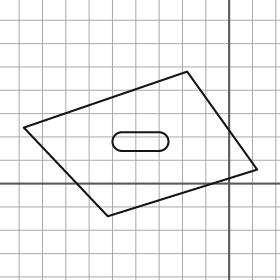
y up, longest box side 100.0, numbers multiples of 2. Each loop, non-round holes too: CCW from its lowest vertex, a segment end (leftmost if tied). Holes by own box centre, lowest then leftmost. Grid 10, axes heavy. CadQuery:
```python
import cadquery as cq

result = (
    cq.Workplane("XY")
    .moveTo(-52.0, -14.0)
    .lineTo(12.0, 6.0)
    .lineTo(-18.0, 48.0)
    .lineTo(-88.0, 24.0)
    .close()
    .moveTo(-46.0, 14.0)
    .lineTo(-30.0, 14.0)
    .threePointArc((-26.0, 18.0), (-30.0, 22.0))
    .lineTo(-46.0, 22.0)
    .threePointArc((-50.0, 18.0), (-46.0, 14.0))
    .close()
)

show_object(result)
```